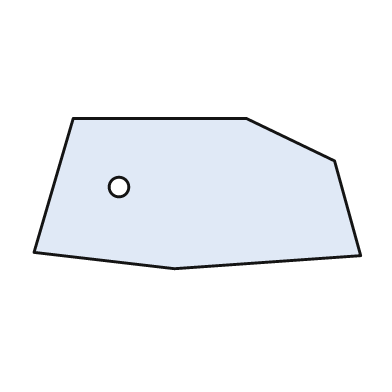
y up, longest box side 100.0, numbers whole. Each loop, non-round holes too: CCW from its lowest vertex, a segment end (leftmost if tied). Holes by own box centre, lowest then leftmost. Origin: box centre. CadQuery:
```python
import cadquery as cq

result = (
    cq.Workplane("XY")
    .moveTo(-7.0, -23.0)
    .lineTo(50.0, -19.0)
    .lineTo(42.0, 10.0)
    .lineTo(15.0, 23.0)
    .lineTo(-38.0, 23.0)
    .lineTo(-50.0, -18.0)
    .close()
    .moveTo(-24.0, 2.0)
    .circle(3.0)
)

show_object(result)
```